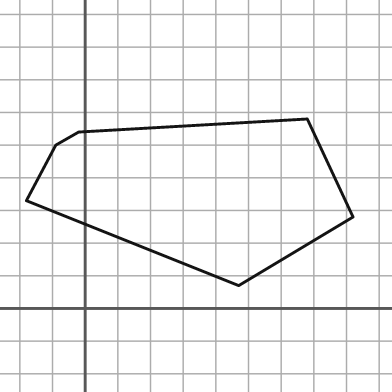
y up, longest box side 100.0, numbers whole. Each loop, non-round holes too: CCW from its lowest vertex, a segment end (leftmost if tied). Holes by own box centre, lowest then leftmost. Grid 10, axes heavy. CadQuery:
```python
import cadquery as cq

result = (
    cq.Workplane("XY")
    .moveTo(47.0, 7.0)
    .lineTo(82.0, 28.0)
    .lineTo(68.0, 58.0)
    .lineTo(-2.0, 54.0)
    .lineTo(-9.0, 50.0)
    .lineTo(-18.0, 33.0)
    .close()
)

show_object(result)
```